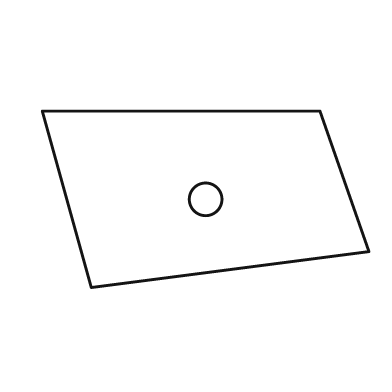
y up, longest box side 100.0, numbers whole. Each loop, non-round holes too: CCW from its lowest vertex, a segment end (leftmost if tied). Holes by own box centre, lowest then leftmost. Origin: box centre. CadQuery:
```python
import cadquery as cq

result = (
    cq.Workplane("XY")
    .moveTo(-35.0, -27.0)
    .lineTo(50.0, -16.0)
    .lineTo(35.0, 27.0)
    .lineTo(-50.0, 27.0)
    .close()
    .moveTo(0.0, 0.0)
    .circle(5.0)
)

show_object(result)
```